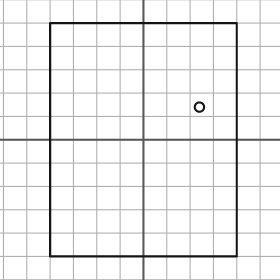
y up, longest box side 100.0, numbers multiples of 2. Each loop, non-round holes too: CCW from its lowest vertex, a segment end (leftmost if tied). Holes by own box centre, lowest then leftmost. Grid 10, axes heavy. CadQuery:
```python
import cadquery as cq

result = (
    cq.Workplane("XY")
    .moveTo(-40.0, -50.0)
    .lineTo(40.0, -50.0)
    .lineTo(40.0, 50.0)
    .lineTo(-40.0, 50.0)
    .close()
    .moveTo(24.0, 14.0)
    .circle(2.0)
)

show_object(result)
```